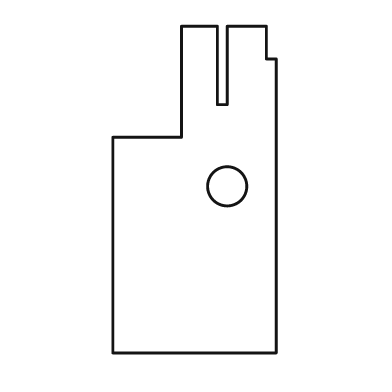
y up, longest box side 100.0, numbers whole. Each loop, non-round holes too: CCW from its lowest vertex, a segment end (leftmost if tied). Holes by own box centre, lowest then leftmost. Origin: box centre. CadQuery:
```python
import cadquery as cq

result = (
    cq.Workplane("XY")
    .moveTo(-25.0, -50.0)
    .lineTo(25.0, -50.0)
    .lineTo(25.0, 40.0)
    .lineTo(22.0, 40.0)
    .lineTo(22.0, 50.0)
    .lineTo(10.0, 50.0)
    .lineTo(10.0, 26.0)
    .lineTo(7.0, 26.0)
    .lineTo(7.0, 50.0)
    .lineTo(-4.0, 50.0)
    .lineTo(-4.0, 16.0)
    .lineTo(-25.0, 16.0)
    .close()
    .moveTo(10.0, 1.0)
    .circle(6.0)
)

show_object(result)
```